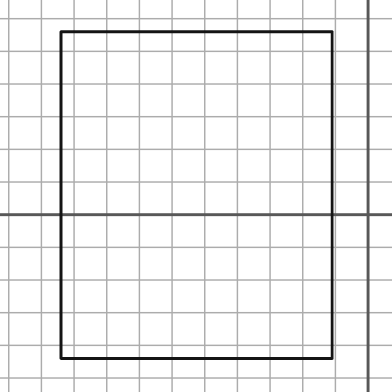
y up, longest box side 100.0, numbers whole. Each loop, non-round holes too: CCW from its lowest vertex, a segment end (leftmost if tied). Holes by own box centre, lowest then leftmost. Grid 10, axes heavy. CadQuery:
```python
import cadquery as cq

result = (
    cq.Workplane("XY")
    .moveTo(-94.0, -44.0)
    .lineTo(-11.0, -44.0)
    .lineTo(-11.0, 56.0)
    .lineTo(-94.0, 56.0)
    .close()
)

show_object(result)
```